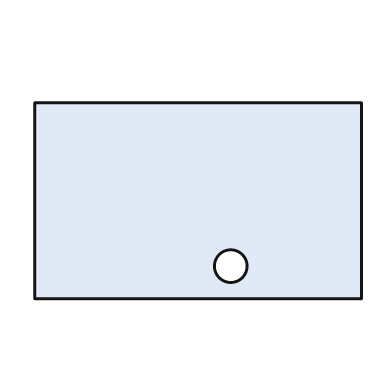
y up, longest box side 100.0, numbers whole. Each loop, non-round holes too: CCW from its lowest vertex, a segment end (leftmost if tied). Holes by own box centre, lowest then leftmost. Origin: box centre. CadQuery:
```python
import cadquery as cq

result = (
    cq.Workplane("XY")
    .moveTo(-50.0, -30.0)
    .lineTo(50.0, -30.0)
    .lineTo(50.0, 30.0)
    .lineTo(-50.0, 30.0)
    .close()
    .moveTo(10.0, -20.0)
    .circle(5.0)
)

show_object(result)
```